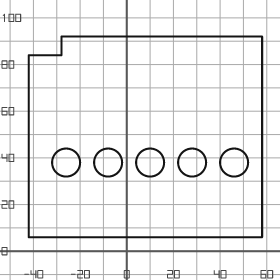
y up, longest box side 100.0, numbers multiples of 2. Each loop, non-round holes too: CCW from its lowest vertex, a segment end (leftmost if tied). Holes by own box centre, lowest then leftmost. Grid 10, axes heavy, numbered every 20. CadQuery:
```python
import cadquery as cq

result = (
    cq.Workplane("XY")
    .moveTo(-42.0, 6.0)
    .lineTo(58.0, 6.0)
    .lineTo(58.0, 92.0)
    .lineTo(-28.0, 92.0)
    .lineTo(-28.0, 84.0)
    .lineTo(-42.0, 84.0)
    .close()
    .moveTo(-26.0, 38.0)
    .circle(6.0)
    .moveTo(-8.0, 38.0)
    .circle(6.0)
    .moveTo(10.0, 38.0)
    .circle(6.0)
    .moveTo(28.0, 38.0)
    .circle(6.0)
    .moveTo(46.0, 38.0)
    .circle(6.0)
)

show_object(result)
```